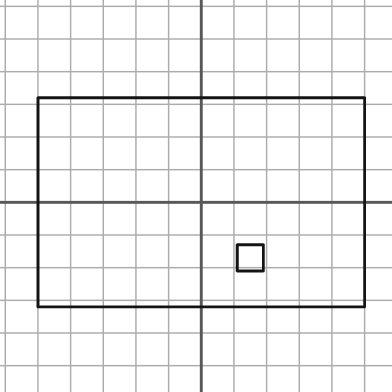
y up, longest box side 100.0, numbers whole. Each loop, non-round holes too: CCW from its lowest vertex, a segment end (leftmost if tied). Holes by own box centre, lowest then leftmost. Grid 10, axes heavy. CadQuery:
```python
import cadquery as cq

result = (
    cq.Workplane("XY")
    .moveTo(-50.0, -32.0)
    .lineTo(50.0, -32.0)
    .lineTo(50.0, 32.0)
    .lineTo(-50.0, 32.0)
    .close()
    .moveTo(11.0, -21.0)
    .lineTo(19.0, -21.0)
    .lineTo(19.0, -13.0)
    .lineTo(11.0, -13.0)
    .close()
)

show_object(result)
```